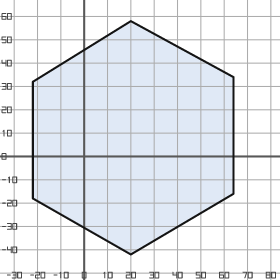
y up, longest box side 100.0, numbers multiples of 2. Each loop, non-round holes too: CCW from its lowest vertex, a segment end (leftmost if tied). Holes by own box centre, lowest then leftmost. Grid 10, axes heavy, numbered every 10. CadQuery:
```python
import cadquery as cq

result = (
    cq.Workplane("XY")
    .moveTo(20.0, -42.0)
    .lineTo(64.0, -16.0)
    .lineTo(64.0, 34.0)
    .lineTo(20.0, 58.0)
    .lineTo(-22.0, 32.0)
    .lineTo(-22.0, -18.0)
    .close()
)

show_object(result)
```